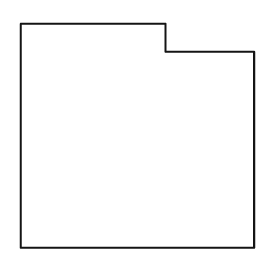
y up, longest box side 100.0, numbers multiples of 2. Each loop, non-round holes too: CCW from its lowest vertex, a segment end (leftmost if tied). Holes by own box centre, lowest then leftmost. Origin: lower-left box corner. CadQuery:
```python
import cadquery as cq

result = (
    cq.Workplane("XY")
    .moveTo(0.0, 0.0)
    .lineTo(100.0, 0.0)
    .lineTo(100.0, 84.0)
    .lineTo(62.0, 84.0)
    .lineTo(62.0, 96.0)
    .lineTo(0.0, 96.0)
    .close()
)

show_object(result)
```